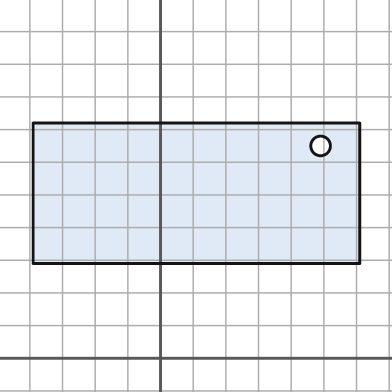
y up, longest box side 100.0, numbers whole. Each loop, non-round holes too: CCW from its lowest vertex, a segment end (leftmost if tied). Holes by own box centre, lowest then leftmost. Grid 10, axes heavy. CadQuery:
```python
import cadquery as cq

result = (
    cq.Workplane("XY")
    .moveTo(-39.0, 29.0)
    .lineTo(61.0, 29.0)
    .lineTo(61.0, 72.0)
    .lineTo(-39.0, 72.0)
    .close()
    .moveTo(49.0, 65.0)
    .circle(3.0)
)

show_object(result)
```